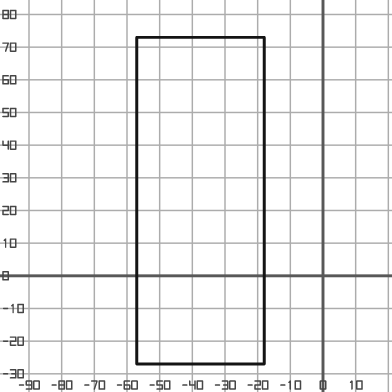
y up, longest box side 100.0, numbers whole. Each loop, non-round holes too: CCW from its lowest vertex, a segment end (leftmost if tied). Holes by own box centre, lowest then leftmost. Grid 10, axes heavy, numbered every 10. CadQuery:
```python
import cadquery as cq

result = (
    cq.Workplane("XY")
    .moveTo(-57.0, -27.0)
    .lineTo(-18.0, -27.0)
    .lineTo(-18.0, 73.0)
    .lineTo(-57.0, 73.0)
    .close()
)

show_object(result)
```